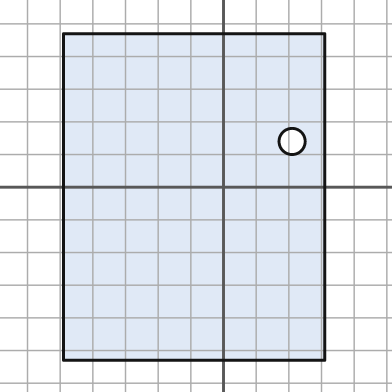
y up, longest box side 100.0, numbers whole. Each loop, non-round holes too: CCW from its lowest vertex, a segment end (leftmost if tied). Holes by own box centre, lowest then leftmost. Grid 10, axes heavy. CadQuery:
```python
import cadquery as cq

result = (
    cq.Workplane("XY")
    .moveTo(-49.0, -53.0)
    .lineTo(31.0, -53.0)
    .lineTo(31.0, 47.0)
    .lineTo(-49.0, 47.0)
    .close()
    .moveTo(21.0, 14.0)
    .circle(4.0)
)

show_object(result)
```